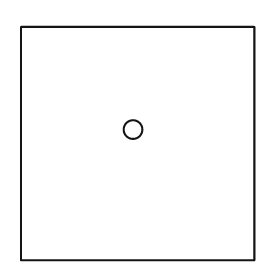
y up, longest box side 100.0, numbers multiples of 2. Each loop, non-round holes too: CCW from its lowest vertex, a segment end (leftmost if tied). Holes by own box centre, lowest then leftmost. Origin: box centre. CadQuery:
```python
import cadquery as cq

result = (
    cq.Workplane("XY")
    .moveTo(-50.0, -50.0)
    .lineTo(50.0, -50.0)
    .lineTo(50.0, 50.0)
    .lineTo(-50.0, 50.0)
    .close()
    .moveTo(-2.0, 6.0)
    .circle(4.0)
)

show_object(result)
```